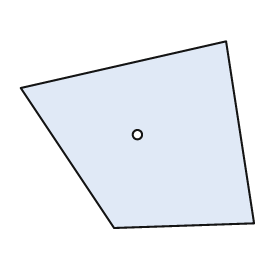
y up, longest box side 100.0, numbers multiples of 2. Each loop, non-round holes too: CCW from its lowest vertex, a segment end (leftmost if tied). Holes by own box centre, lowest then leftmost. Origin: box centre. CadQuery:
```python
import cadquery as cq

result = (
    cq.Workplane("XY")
    .moveTo(-10.0, -40.0)
    .lineTo(50.0, -38.0)
    .lineTo(38.0, 40.0)
    .lineTo(-50.0, 20.0)
    .close()
    .moveTo(0.0, 0.0)
    .circle(2.0)
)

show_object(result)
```